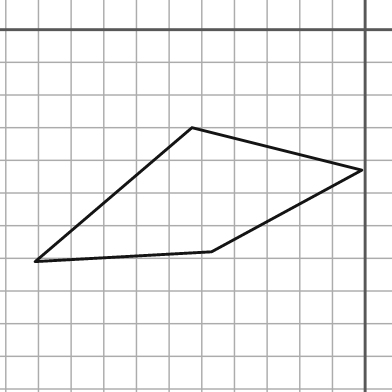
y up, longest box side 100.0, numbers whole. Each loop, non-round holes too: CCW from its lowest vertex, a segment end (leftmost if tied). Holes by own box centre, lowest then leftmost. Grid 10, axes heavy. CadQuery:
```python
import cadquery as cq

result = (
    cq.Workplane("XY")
    .moveTo(-101.0, -71.0)
    .lineTo(-47.0, -68.0)
    .lineTo(-1.0, -43.0)
    .lineTo(-53.0, -30.0)
    .close()
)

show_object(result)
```